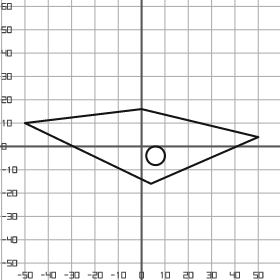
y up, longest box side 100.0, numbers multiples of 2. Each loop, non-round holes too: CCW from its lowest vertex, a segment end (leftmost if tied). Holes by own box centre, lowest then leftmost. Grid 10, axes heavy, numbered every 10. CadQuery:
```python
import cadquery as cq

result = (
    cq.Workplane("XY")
    .moveTo(4.0, -16.0)
    .lineTo(50.0, 4.0)
    .lineTo(0.0, 16.0)
    .lineTo(-50.0, 10.0)
    .close()
    .moveTo(6.0, -4.0)
    .circle(4.0)
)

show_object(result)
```